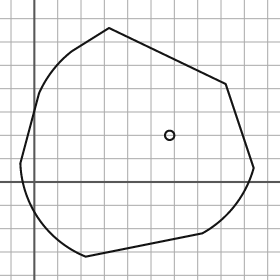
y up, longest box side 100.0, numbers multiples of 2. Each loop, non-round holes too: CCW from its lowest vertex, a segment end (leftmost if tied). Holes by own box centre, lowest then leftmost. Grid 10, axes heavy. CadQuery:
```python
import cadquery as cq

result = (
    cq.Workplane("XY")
    .moveTo(22.0, -32.0)
    .lineTo(72.0, -22.0)
    .threePointArc((86.0, -10.0), (94.0, 6.0))
    .lineTo(82.0, 42.0)
    .lineTo(32.0, 66.0)
    .lineTo(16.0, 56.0)
    .threePointArc((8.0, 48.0), (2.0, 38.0))
    .lineTo(-6.0, 8.0)
    .threePointArc((2.0, -16.0), (22.0, -32.0))
    .close()
    .moveTo(58.0, 20.0)
    .circle(2.0)
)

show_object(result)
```